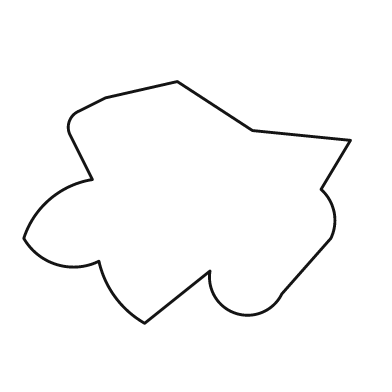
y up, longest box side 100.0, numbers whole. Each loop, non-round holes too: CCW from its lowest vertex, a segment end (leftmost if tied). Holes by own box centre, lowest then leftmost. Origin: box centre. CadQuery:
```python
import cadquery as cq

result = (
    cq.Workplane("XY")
    .moveTo(-13.0, -37.0)
    .lineTo(7.0, -21.0)
    .threePointArc((15.0, -34.0), (29.0, -28.0))
    .lineTo(44.0, -11.0)
    .threePointArc((45.0, -3.0), (41.0, 4.0))
    .lineTo(50.0, 19.0)
    .lineTo(20.0, 22.0)
    .lineTo(-3.0, 37.0)
    .lineTo(-25.0, 32.0)
    .lineTo(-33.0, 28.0)
    .threePointArc((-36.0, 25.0), (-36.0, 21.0))
    .lineTo(-29.0, 7.0)
    .threePointArc((-42.0, 1.0), (-50.0, -11.0))
    .threePointArc((-40.0, -19.0), (-27.0, -18.0))
    .threePointArc((-22.0, -29.0), (-13.0, -37.0))
    .close()
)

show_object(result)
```